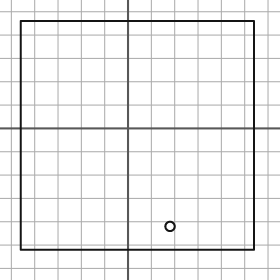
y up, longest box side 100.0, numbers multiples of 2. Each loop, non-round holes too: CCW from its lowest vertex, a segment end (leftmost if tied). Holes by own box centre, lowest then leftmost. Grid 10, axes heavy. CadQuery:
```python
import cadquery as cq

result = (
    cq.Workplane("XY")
    .moveTo(-46.0, -52.0)
    .lineTo(54.0, -52.0)
    .lineTo(54.0, 46.0)
    .lineTo(-46.0, 46.0)
    .close()
    .moveTo(18.0, -42.0)
    .circle(2.0)
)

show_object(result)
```